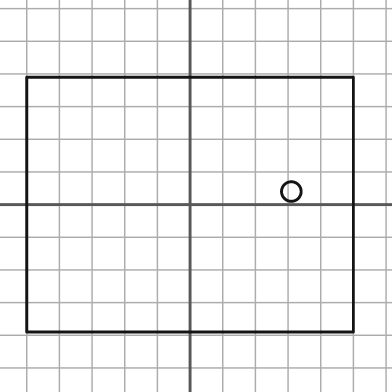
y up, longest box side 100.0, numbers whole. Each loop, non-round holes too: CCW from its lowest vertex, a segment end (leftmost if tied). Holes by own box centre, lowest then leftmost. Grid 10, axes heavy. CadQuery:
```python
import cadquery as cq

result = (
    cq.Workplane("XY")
    .moveTo(-50.0, -39.0)
    .lineTo(50.0, -39.0)
    .lineTo(50.0, 39.0)
    .lineTo(-50.0, 39.0)
    .close()
    .moveTo(31.0, 4.0)
    .circle(3.0)
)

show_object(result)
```